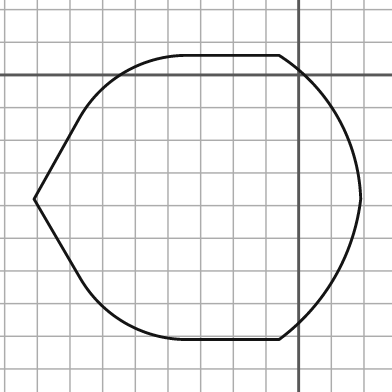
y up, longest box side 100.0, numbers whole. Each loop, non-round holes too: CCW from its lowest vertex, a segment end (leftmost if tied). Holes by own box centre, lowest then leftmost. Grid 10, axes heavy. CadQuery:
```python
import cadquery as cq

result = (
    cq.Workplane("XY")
    .moveTo(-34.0, -81.0)
    .lineTo(-6.0, -81.0)
    .threePointArc((11.0, -62.0), (19.0, -38.0))
    .threePointArc((12.0, -13.0), (-6.0, 6.0))
    .lineTo(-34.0, 6.0)
    .threePointArc((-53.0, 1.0), (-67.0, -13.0))
    .lineTo(-81.0, -38.0)
    .lineTo(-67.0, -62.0)
    .threePointArc((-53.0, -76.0), (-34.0, -81.0))
    .close()
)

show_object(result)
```